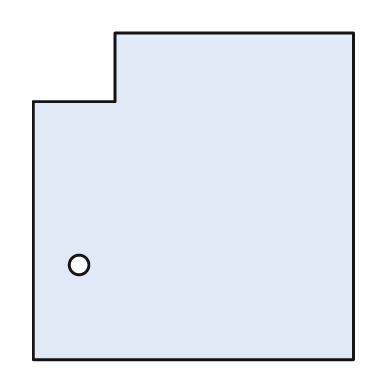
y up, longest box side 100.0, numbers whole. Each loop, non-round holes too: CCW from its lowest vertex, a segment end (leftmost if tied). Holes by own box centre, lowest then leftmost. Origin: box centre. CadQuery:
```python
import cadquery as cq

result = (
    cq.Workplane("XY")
    .moveTo(-49.0, -50.0)
    .lineTo(49.0, -50.0)
    .lineTo(49.0, 50.0)
    .lineTo(-24.0, 50.0)
    .lineTo(-24.0, 29.0)
    .lineTo(-49.0, 29.0)
    .close()
    .moveTo(-35.0, -21.0)
    .circle(3.0)
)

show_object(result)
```